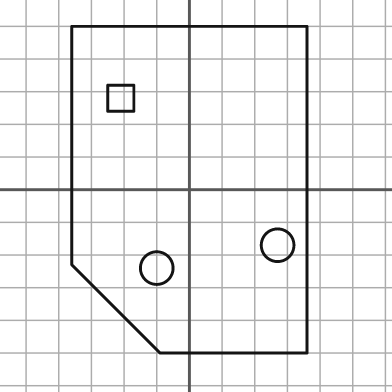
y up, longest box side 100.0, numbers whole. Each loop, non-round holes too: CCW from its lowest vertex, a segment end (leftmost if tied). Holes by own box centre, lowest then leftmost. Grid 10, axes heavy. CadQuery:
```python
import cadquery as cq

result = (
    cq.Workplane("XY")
    .moveTo(-9.0, -50.0)
    .lineTo(36.0, -50.0)
    .lineTo(36.0, 50.0)
    .lineTo(-36.0, 50.0)
    .lineTo(-36.0, -23.0)
    .close()
    .moveTo(-10.0, -24.0)
    .circle(5.0)
    .moveTo(27.0, -17.0)
    .circle(5.0)
    .moveTo(-25.0, 24.0)
    .lineTo(-17.0, 24.0)
    .lineTo(-17.0, 32.0)
    .lineTo(-25.0, 32.0)
    .close()
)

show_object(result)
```